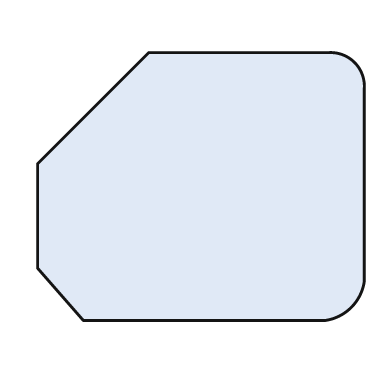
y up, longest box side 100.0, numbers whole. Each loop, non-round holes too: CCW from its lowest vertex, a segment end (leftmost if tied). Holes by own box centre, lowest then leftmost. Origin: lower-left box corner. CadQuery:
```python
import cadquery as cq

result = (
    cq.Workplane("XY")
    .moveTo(14.0, 0.0)
    .lineTo(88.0, 0.0)
    .threePointArc((96.0, 4.0), (100.0, 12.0))
    .lineTo(100.0, 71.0)
    .threePointArc((97.0, 79.0), (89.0, 82.0))
    .lineTo(34.0, 82.0)
    .lineTo(0.0, 48.0)
    .lineTo(0.0, 16.0)
    .close()
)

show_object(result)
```